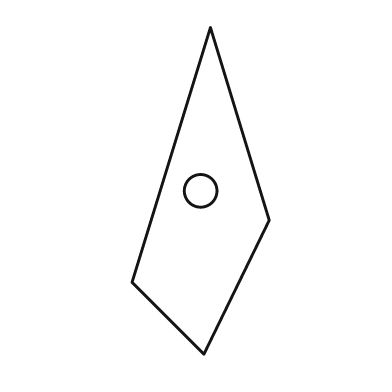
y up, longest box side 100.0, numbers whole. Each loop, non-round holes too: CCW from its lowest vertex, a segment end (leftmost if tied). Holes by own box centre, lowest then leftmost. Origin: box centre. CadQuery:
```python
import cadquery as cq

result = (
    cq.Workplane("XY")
    .moveTo(1.0, -50.0)
    .lineTo(21.0, -9.0)
    .lineTo(3.0, 50.0)
    .lineTo(-21.0, -28.0)
    .close()
    .moveTo(0.0, 0.0)
    .circle(5.0)
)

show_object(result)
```